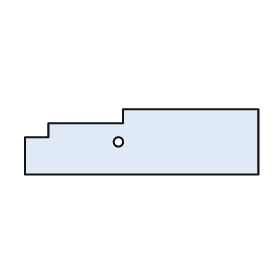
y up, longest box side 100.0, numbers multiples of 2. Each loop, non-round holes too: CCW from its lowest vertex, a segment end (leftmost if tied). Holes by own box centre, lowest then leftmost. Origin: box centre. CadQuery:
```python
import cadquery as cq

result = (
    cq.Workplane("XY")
    .moveTo(-50.0, -14.0)
    .lineTo(50.0, -14.0)
    .lineTo(50.0, 14.0)
    .lineTo(-8.0, 14.0)
    .lineTo(-8.0, 8.0)
    .lineTo(-40.0, 8.0)
    .lineTo(-40.0, 2.0)
    .lineTo(-50.0, 2.0)
    .close()
    .moveTo(-10.0, 0.0)
    .circle(2.0)
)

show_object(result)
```